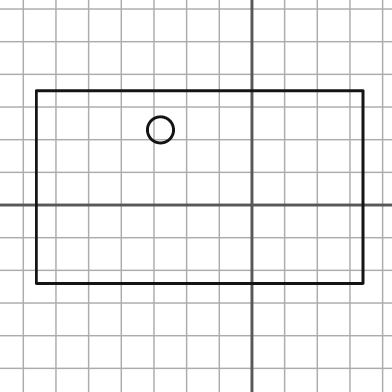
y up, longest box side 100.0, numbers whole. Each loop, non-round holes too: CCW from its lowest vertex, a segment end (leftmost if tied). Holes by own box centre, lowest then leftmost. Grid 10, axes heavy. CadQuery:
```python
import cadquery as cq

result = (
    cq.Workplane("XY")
    .moveTo(-66.0, -24.0)
    .lineTo(34.0, -24.0)
    .lineTo(34.0, 35.0)
    .lineTo(-66.0, 35.0)
    .close()
    .moveTo(-28.0, 23.0)
    .circle(4.0)
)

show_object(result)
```